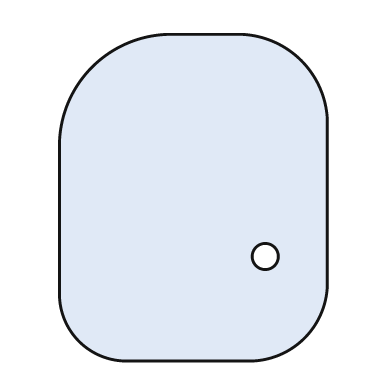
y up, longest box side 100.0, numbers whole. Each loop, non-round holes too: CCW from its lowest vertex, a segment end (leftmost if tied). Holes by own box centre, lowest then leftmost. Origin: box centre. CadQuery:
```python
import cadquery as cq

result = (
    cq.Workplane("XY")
    .moveTo(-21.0, -50.0)
    .lineTo(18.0, -50.0)
    .threePointArc((34.0, -43.0), (41.0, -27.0))
    .lineTo(41.0, 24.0)
    .threePointArc((33.0, 42.0), (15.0, 50.0))
    .lineTo(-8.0, 50.0)
    .threePointArc((-31.0, 40.0), (-41.0, 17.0))
    .lineTo(-41.0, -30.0)
    .threePointArc((-35.0, -44.0), (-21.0, -50.0))
    .close()
    .moveTo(22.0, -18.0)
    .circle(4.0)
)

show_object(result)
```